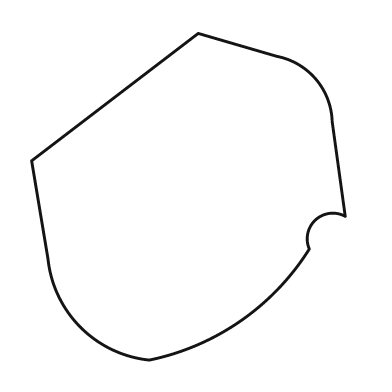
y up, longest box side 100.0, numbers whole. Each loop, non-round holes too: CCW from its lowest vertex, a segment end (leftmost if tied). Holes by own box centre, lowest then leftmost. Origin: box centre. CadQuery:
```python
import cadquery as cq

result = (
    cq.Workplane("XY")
    .moveTo(-12.0, -50.0)
    .threePointArc((16.0, -38.0), (37.0, -16.0))
    .threePointArc((39.0, -7.0), (48.0, -6.0))
    .lineTo(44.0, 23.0)
    .threePointArc((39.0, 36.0), (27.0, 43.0))
    .lineTo(3.0, 50.0)
    .lineTo(-48.0, 11.0)
    .lineTo(-43.0, -19.0)
    .threePointArc((-33.0, -40.0), (-12.0, -50.0))
    .close()
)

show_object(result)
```